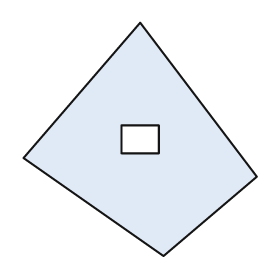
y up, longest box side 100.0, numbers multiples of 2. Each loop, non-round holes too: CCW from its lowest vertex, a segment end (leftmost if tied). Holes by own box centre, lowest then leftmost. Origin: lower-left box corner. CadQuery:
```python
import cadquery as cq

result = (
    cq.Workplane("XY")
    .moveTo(60.0, 0.0)
    .lineTo(100.0, 34.0)
    .lineTo(50.0, 100.0)
    .lineTo(0.0, 42.0)
    .close()
    .moveTo(42.0, 44.0)
    .lineTo(58.0, 44.0)
    .lineTo(58.0, 56.0)
    .lineTo(42.0, 56.0)
    .close()
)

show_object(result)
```